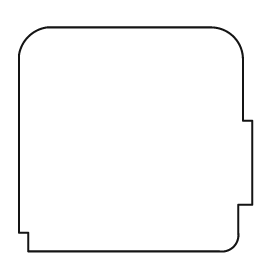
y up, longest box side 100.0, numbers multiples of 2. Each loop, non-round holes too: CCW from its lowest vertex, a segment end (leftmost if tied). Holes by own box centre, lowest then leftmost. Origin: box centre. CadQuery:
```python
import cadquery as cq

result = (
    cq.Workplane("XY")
    .moveTo(-46.0, -48.0)
    .lineTo(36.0, -48.0)
    .threePointArc((42.0, -46.0), (44.0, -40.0))
    .lineTo(44.0, -28.0)
    .lineTo(50.0, -28.0)
    .lineTo(50.0, 8.0)
    .lineTo(46.0, 8.0)
    .lineTo(46.0, 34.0)
    .threePointArc((42.0, 44.0), (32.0, 48.0))
    .lineTo(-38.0, 48.0)
    .threePointArc((-46.0, 44.0), (-50.0, 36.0))
    .lineTo(-50.0, -40.0)
    .lineTo(-46.0, -40.0)
    .close()
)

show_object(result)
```